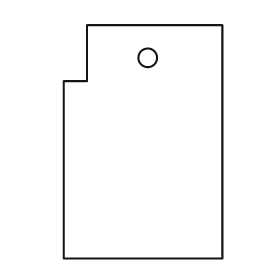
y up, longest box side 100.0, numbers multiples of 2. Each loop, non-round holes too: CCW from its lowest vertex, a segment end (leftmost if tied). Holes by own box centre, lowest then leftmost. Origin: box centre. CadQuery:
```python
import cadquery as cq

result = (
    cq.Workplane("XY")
    .moveTo(-34.0, -50.0)
    .lineTo(34.0, -50.0)
    .lineTo(34.0, 50.0)
    .lineTo(-24.0, 50.0)
    .lineTo(-24.0, 26.0)
    .lineTo(-34.0, 26.0)
    .close()
    .moveTo(2.0, 36.0)
    .circle(4.0)
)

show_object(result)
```